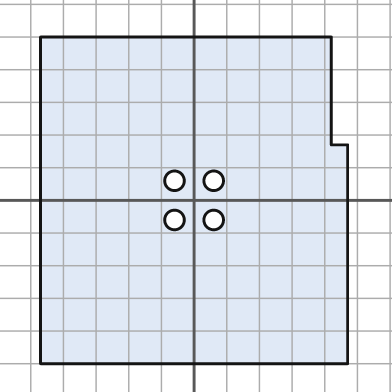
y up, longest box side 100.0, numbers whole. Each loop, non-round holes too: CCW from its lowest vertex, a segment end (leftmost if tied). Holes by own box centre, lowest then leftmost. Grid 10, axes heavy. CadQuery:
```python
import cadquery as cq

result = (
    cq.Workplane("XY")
    .moveTo(-47.0, -50.0)
    .lineTo(47.0, -50.0)
    .lineTo(47.0, 17.0)
    .lineTo(42.0, 17.0)
    .lineTo(42.0, 50.0)
    .lineTo(-47.0, 50.0)
    .close()
    .moveTo(-6.0, -6.0)
    .circle(3.0)
    .moveTo(6.0, -6.0)
    .circle(3.0)
    .moveTo(-6.0, 6.0)
    .circle(3.0)
    .moveTo(6.0, 6.0)
    .circle(3.0)
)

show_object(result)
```